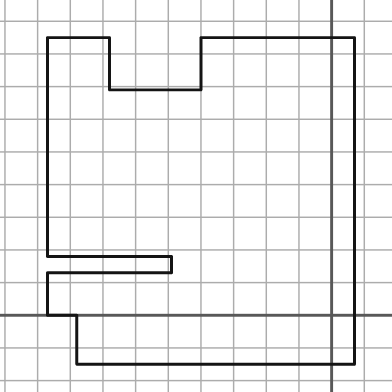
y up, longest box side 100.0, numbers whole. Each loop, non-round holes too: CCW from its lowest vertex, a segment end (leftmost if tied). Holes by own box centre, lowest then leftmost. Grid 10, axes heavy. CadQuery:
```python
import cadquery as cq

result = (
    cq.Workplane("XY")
    .moveTo(-78.0, -15.0)
    .lineTo(7.0, -15.0)
    .lineTo(7.0, 85.0)
    .lineTo(-40.0, 85.0)
    .lineTo(-40.0, 69.0)
    .lineTo(-68.0, 69.0)
    .lineTo(-68.0, 85.0)
    .lineTo(-87.0, 85.0)
    .lineTo(-87.0, 18.0)
    .lineTo(-49.0, 18.0)
    .lineTo(-49.0, 13.0)
    .lineTo(-87.0, 13.0)
    .lineTo(-87.0, 0.0)
    .lineTo(-78.0, 0.0)
    .close()
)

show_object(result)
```